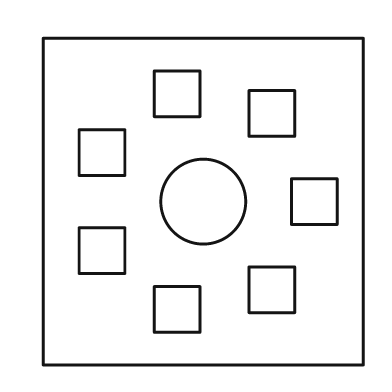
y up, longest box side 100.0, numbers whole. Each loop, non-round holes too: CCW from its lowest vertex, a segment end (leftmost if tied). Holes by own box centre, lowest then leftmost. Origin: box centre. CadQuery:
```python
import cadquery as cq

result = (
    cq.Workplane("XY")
    .moveTo(-49.0, -50.0)
    .lineTo(49.0, -50.0)
    .lineTo(49.0, 50.0)
    .lineTo(-49.0, 50.0)
    .close()
    .moveTo(-15.0, -40.0)
    .lineTo(-1.0, -40.0)
    .lineTo(-1.0, -26.0)
    .lineTo(-15.0, -26.0)
    .close()
    .moveTo(14.0, -34.0)
    .lineTo(28.0, -34.0)
    .lineTo(28.0, -20.0)
    .lineTo(14.0, -20.0)
    .close()
    .moveTo(-38.0, -22.0)
    .lineTo(-24.0, -22.0)
    .lineTo(-24.0, -8.0)
    .lineTo(-38.0, -8.0)
    .close()
    .moveTo(0.0, 0.0)
    .circle(13.0)
    .moveTo(27.0, -7.0)
    .lineTo(41.0, -7.0)
    .lineTo(41.0, 7.0)
    .lineTo(27.0, 7.0)
    .close()
    .moveTo(-38.0, 8.0)
    .lineTo(-24.0, 8.0)
    .lineTo(-24.0, 22.0)
    .lineTo(-38.0, 22.0)
    .close()
    .moveTo(14.0, 20.0)
    .lineTo(28.0, 20.0)
    .lineTo(28.0, 34.0)
    .lineTo(14.0, 34.0)
    .close()
    .moveTo(-15.0, 26.0)
    .lineTo(-1.0, 26.0)
    .lineTo(-1.0, 40.0)
    .lineTo(-15.0, 40.0)
    .close()
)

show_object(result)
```